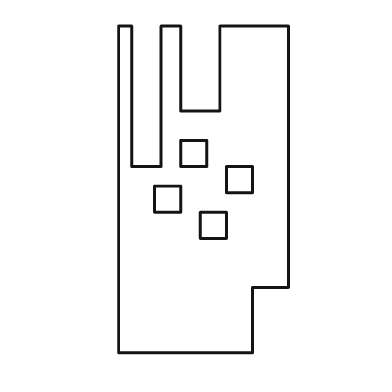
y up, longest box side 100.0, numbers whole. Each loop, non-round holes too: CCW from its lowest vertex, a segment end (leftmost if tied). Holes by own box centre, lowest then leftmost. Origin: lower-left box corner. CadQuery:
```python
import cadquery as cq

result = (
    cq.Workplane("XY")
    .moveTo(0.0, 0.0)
    .lineTo(41.0, 0.0)
    .lineTo(41.0, 20.0)
    .lineTo(52.0, 20.0)
    .lineTo(52.0, 100.0)
    .lineTo(31.0, 100.0)
    .lineTo(31.0, 74.0)
    .lineTo(19.0, 74.0)
    .lineTo(19.0, 100.0)
    .lineTo(13.0, 100.0)
    .lineTo(13.0, 57.0)
    .lineTo(4.0, 57.0)
    .lineTo(4.0, 100.0)
    .lineTo(0.0, 100.0)
    .close()
    .moveTo(25.0, 35.0)
    .lineTo(33.0, 35.0)
    .lineTo(33.0, 43.0)
    .lineTo(25.0, 43.0)
    .close()
    .moveTo(11.0, 43.0)
    .lineTo(19.0, 43.0)
    .lineTo(19.0, 51.0)
    .lineTo(11.0, 51.0)
    .close()
    .moveTo(33.0, 49.0)
    .lineTo(41.0, 49.0)
    .lineTo(41.0, 57.0)
    .lineTo(33.0, 57.0)
    .close()
    .moveTo(19.0, 57.0)
    .lineTo(27.0, 57.0)
    .lineTo(27.0, 65.0)
    .lineTo(19.0, 65.0)
    .close()
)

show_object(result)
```